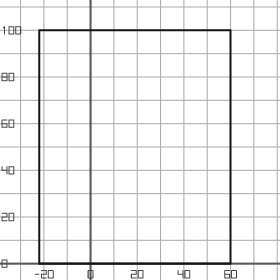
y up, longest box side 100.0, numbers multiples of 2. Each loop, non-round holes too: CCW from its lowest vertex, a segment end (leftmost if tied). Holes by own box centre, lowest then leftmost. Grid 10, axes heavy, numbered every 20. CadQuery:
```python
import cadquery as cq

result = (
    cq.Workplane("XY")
    .moveTo(-22.0, 0.0)
    .lineTo(60.0, 0.0)
    .lineTo(60.0, 100.0)
    .lineTo(-22.0, 100.0)
    .close()
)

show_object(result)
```